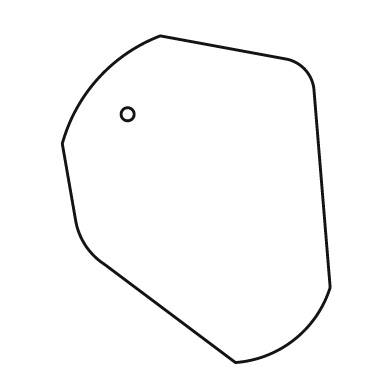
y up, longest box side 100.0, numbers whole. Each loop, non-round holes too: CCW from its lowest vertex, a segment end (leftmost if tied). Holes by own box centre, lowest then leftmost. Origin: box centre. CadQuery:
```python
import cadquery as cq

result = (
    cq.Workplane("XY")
    .moveTo(12.0, -50.0)
    .threePointArc((30.0, -43.0), (41.0, -27.0))
    .lineTo(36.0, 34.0)
    .threePointArc((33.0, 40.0), (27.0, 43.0))
    .lineTo(-11.0, 50.0)
    .threePointArc((-30.0, 37.0), (-41.0, 17.0))
    .lineTo(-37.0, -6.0)
    .threePointArc((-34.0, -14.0), (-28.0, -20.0))
    .close()
    .moveTo(-21.0, 26.0)
    .circle(2.0)
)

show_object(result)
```